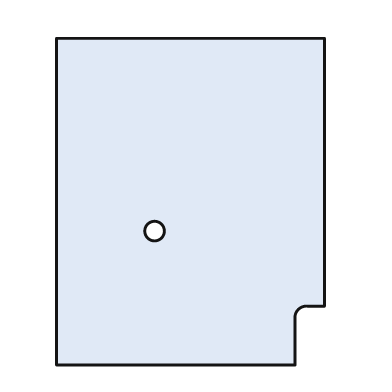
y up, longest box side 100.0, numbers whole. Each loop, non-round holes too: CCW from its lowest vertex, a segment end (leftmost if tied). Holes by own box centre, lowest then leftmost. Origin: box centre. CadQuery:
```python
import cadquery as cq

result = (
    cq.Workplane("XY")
    .moveTo(-41.0, -50.0)
    .lineTo(32.0, -50.0)
    .lineTo(32.0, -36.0)
    .threePointArc((33.0, -33.0), (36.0, -32.0))
    .lineTo(41.0, -32.0)
    .lineTo(41.0, 50.0)
    .lineTo(-41.0, 50.0)
    .close()
    .moveTo(-11.0, -9.0)
    .circle(3.0)
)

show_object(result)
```